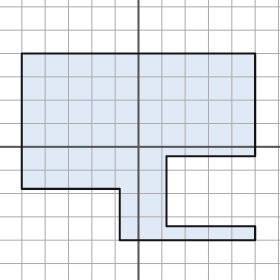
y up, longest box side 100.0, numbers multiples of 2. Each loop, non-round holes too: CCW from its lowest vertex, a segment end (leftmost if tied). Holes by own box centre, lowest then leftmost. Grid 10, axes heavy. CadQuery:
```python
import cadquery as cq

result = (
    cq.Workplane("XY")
    .moveTo(-8.0, -40.0)
    .lineTo(50.0, -40.0)
    .lineTo(50.0, -34.0)
    .lineTo(12.0, -34.0)
    .lineTo(12.0, -4.0)
    .lineTo(50.0, -4.0)
    .lineTo(50.0, 40.0)
    .lineTo(-50.0, 40.0)
    .lineTo(-50.0, -18.0)
    .lineTo(-8.0, -18.0)
    .close()
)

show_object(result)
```